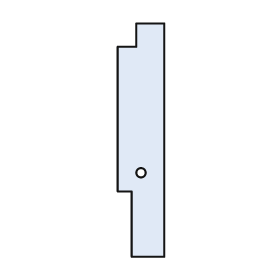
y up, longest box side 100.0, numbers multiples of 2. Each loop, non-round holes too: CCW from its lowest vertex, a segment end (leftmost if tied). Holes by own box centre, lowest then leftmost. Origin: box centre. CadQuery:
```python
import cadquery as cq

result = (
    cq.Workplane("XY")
    .moveTo(-4.0, -50.0)
    .lineTo(10.0, -50.0)
    .lineTo(10.0, 50.0)
    .lineTo(-2.0, 50.0)
    .lineTo(-2.0, 40.0)
    .lineTo(-10.0, 40.0)
    .lineTo(-10.0, -22.0)
    .lineTo(-4.0, -22.0)
    .close()
    .moveTo(0.0, -14.0)
    .circle(2.0)
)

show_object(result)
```